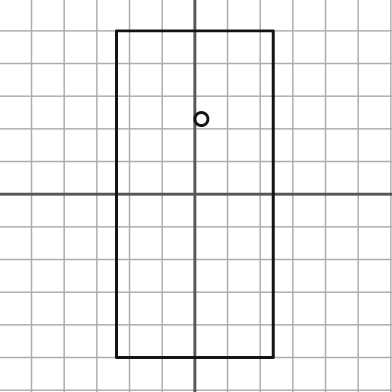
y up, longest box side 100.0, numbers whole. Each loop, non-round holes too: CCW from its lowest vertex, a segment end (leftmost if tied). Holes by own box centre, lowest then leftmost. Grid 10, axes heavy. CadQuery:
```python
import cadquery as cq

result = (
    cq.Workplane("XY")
    .moveTo(-24.0, -50.0)
    .lineTo(24.0, -50.0)
    .lineTo(24.0, 50.0)
    .lineTo(-24.0, 50.0)
    .close()
    .moveTo(2.0, 23.0)
    .circle(2.0)
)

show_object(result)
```